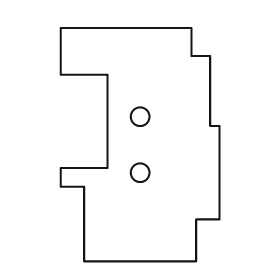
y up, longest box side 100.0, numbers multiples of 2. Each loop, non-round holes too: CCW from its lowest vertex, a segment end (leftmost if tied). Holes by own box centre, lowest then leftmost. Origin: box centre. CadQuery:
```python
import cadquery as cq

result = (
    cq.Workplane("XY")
    .moveTo(-24.0, -50.0)
    .lineTo(24.0, -50.0)
    .lineTo(24.0, -32.0)
    .lineTo(34.0, -32.0)
    .lineTo(34.0, 8.0)
    .lineTo(30.0, 8.0)
    .lineTo(30.0, 38.0)
    .lineTo(22.0, 38.0)
    .lineTo(22.0, 50.0)
    .lineTo(-34.0, 50.0)
    .lineTo(-34.0, 30.0)
    .lineTo(-14.0, 30.0)
    .lineTo(-14.0, -10.0)
    .lineTo(-34.0, -10.0)
    .lineTo(-34.0, -18.0)
    .lineTo(-24.0, -18.0)
    .close()
    .moveTo(0.0, -12.0)
    .circle(4.0)
    .moveTo(0.0, 12.0)
    .circle(4.0)
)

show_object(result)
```